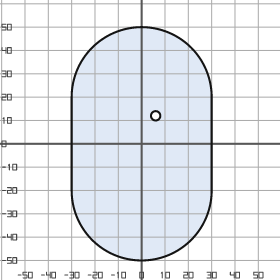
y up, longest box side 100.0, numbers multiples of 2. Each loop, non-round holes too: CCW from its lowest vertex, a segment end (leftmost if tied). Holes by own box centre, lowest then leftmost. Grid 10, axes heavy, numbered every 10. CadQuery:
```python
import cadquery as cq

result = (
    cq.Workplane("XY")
    .moveTo(-30.0, -20.0)
    .threePointArc((0.0, -50.0), (30.0, -20.0))
    .lineTo(30.0, 20.0)
    .threePointArc((0.0, 50.0), (-30.0, 20.0))
    .close()
    .moveTo(6.0, 12.0)
    .circle(2.0)
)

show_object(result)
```